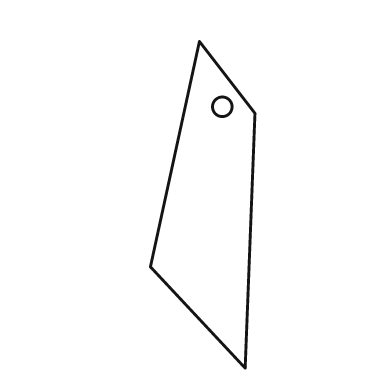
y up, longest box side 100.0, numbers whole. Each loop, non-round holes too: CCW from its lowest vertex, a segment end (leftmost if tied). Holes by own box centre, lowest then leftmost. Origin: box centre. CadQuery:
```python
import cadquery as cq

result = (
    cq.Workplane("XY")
    .moveTo(13.0, -50.0)
    .lineTo(16.0, 28.0)
    .lineTo(-1.0, 50.0)
    .lineTo(-16.0, -19.0)
    .close()
    .moveTo(6.0, 30.0)
    .circle(3.0)
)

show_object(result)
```